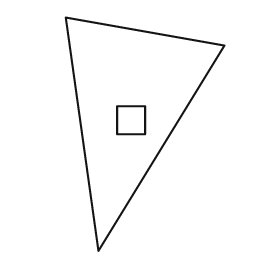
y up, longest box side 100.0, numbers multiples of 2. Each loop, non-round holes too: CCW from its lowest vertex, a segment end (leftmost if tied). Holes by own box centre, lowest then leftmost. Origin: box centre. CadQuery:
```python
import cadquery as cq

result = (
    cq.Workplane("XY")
    .moveTo(-20.0, -50.0)
    .lineTo(34.0, 38.0)
    .lineTo(-34.0, 50.0)
    .close()
    .moveTo(-12.0, 0.0)
    .lineTo(0.0, 0.0)
    .lineTo(0.0, 12.0)
    .lineTo(-12.0, 12.0)
    .close()
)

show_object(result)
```